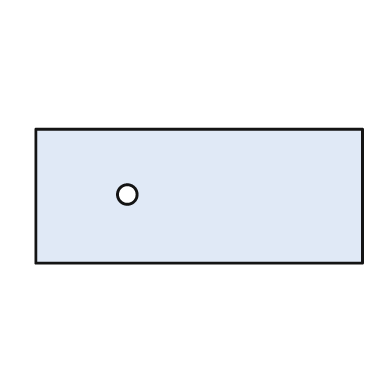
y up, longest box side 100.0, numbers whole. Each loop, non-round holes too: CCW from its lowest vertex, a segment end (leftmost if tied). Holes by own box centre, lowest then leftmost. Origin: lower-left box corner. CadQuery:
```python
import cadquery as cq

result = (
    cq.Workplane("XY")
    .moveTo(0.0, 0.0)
    .lineTo(100.0, 0.0)
    .lineTo(100.0, 41.0)
    .lineTo(0.0, 41.0)
    .close()
    .moveTo(28.0, 21.0)
    .circle(3.0)
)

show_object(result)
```